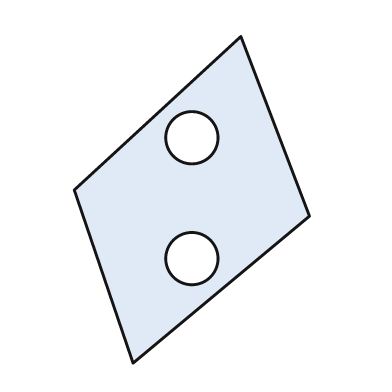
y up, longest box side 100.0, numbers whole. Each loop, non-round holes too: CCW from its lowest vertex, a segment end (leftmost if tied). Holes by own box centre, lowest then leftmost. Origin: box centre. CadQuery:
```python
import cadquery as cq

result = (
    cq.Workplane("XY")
    .moveTo(-18.0, -50.0)
    .lineTo(36.0, -5.0)
    .lineTo(15.0, 50.0)
    .lineTo(-36.0, 3.0)
    .close()
    .moveTo(0.0, -18.0)
    .circle(8.0)
    .moveTo(0.0, 19.0)
    .circle(8.0)
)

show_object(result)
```